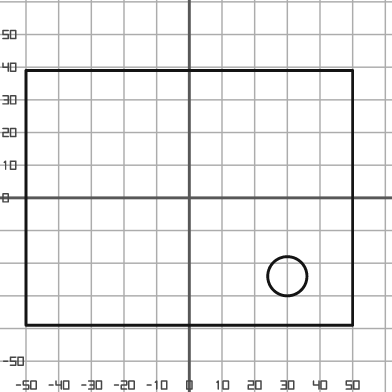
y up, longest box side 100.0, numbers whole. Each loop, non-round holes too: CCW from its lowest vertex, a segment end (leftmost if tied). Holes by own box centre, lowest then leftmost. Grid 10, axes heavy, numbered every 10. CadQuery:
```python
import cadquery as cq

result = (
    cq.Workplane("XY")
    .moveTo(-50.0, -39.0)
    .lineTo(50.0, -39.0)
    .lineTo(50.0, 39.0)
    .lineTo(-50.0, 39.0)
    .close()
    .moveTo(30.0, -24.0)
    .circle(6.0)
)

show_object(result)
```